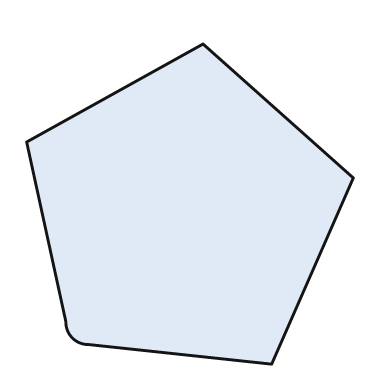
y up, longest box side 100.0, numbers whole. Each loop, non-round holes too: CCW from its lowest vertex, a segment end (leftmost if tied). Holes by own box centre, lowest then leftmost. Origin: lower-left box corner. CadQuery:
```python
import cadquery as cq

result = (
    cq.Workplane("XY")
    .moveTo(75.0, 0.0)
    .lineTo(100.0, 57.0)
    .lineTo(54.0, 98.0)
    .lineTo(0.0, 68.0)
    .lineTo(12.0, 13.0)
    .threePointArc((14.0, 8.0), (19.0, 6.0))
    .close()
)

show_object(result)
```